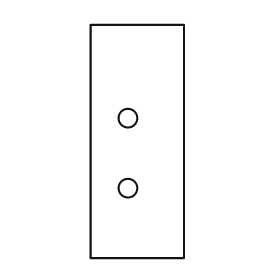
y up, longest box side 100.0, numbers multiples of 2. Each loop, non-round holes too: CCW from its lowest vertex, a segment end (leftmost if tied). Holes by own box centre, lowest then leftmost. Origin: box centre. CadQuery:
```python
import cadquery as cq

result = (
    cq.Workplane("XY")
    .moveTo(-20.0, -50.0)
    .lineTo(20.0, -50.0)
    .lineTo(20.0, 50.0)
    .lineTo(-20.0, 50.0)
    .close()
    .moveTo(-4.0, -20.0)
    .circle(4.0)
    .moveTo(-4.0, 10.0)
    .circle(4.0)
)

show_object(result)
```